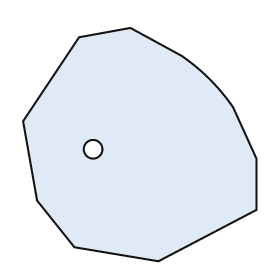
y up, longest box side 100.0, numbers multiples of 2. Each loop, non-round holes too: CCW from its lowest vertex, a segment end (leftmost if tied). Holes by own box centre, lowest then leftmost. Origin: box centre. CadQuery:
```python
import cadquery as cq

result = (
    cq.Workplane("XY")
    .moveTo(8.0, -50.0)
    .lineTo(50.0, -28.0)
    .lineTo(50.0, -6.0)
    .lineTo(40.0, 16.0)
    .threePointArc((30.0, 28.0), (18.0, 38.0))
    .lineTo(-4.0, 50.0)
    .lineTo(-26.0, 46.0)
    .lineTo(-50.0, 10.0)
    .lineTo(-44.0, -24.0)
    .lineTo(-28.0, -44.0)
    .close()
    .moveTo(-20.0, -2.0)
    .circle(4.0)
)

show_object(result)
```